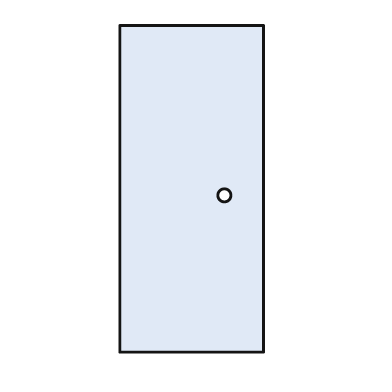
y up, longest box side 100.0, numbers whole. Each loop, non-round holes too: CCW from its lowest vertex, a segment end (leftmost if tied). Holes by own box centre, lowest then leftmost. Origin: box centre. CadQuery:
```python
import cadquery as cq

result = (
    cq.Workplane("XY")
    .moveTo(-22.0, -50.0)
    .lineTo(22.0, -50.0)
    .lineTo(22.0, 50.0)
    .lineTo(-22.0, 50.0)
    .close()
    .moveTo(10.0, -2.0)
    .circle(2.0)
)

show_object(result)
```